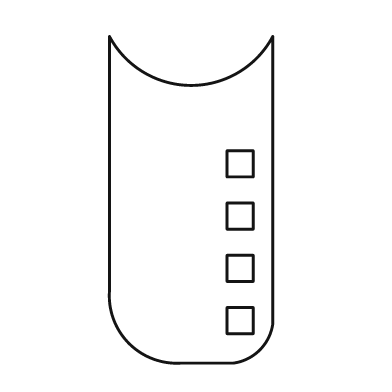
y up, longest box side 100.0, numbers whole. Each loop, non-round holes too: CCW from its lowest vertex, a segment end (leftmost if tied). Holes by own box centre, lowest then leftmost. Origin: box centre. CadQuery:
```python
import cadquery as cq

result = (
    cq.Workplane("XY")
    .moveTo(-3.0, -50.0)
    .lineTo(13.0, -50.0)
    .threePointArc((21.0, -46.0), (25.0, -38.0))
    .lineTo(25.0, 50.0)
    .threePointArc((0.0, 35.0), (-25.0, 50.0))
    .lineTo(-25.0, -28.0)
    .threePointArc((-19.0, -44.0), (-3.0, -50.0))
    .close()
    .moveTo(11.0, -41.0)
    .lineTo(19.0, -41.0)
    .lineTo(19.0, -33.0)
    .lineTo(11.0, -33.0)
    .close()
    .moveTo(11.0, -25.0)
    .lineTo(19.0, -25.0)
    .lineTo(19.0, -17.0)
    .lineTo(11.0, -17.0)
    .close()
    .moveTo(11.0, -9.0)
    .lineTo(19.0, -9.0)
    .lineTo(19.0, -1.0)
    .lineTo(11.0, -1.0)
    .close()
    .moveTo(11.0, 7.0)
    .lineTo(19.0, 7.0)
    .lineTo(19.0, 15.0)
    .lineTo(11.0, 15.0)
    .close()
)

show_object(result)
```